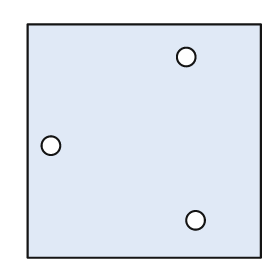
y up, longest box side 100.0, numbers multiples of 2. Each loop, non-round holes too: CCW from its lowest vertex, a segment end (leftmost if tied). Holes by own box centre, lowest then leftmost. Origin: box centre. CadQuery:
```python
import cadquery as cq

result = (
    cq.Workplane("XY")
    .moveTo(-50.0, -50.0)
    .lineTo(50.0, -50.0)
    .lineTo(50.0, 50.0)
    .lineTo(-50.0, 50.0)
    .close()
    .moveTo(22.0, -34.0)
    .circle(4.0)
    .moveTo(-40.0, -2.0)
    .circle(4.0)
    .moveTo(18.0, 36.0)
    .circle(4.0)
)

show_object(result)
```